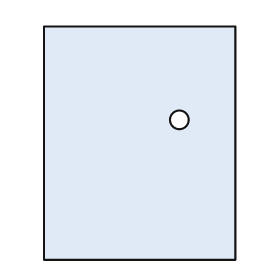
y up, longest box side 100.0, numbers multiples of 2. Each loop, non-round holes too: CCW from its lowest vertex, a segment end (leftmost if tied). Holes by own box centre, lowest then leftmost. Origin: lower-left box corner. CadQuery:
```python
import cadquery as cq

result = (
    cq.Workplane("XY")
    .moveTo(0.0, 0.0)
    .lineTo(82.0, 0.0)
    .lineTo(82.0, 100.0)
    .lineTo(0.0, 100.0)
    .close()
    .moveTo(58.0, 60.0)
    .circle(4.0)
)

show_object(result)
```